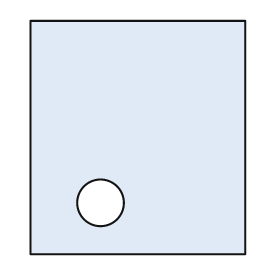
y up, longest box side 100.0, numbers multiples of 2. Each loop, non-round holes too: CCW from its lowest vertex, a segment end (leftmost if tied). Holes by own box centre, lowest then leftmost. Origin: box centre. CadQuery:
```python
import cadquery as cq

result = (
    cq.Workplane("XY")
    .moveTo(-46.0, -50.0)
    .lineTo(46.0, -50.0)
    .lineTo(46.0, 50.0)
    .lineTo(-46.0, 50.0)
    .close()
    .moveTo(-16.0, -28.0)
    .circle(10.0)
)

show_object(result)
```